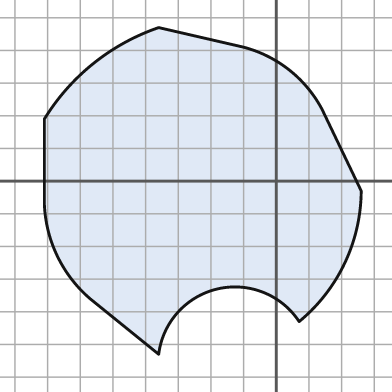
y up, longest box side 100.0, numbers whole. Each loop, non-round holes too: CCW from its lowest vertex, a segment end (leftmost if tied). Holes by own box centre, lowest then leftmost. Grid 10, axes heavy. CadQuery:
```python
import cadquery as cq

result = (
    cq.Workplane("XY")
    .moveTo(-36.0, -53.0)
    .threePointArc((-18.0, -33.0), (7.0, -43.0))
    .threePointArc((21.0, -25.0), (26.0, -3.0))
    .lineTo(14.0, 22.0)
    .threePointArc((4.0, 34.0), (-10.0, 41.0))
    .lineTo(-36.0, 47.0)
    .threePointArc((-56.0, 36.0), (-71.0, 19.0))
    .lineTo(-71.0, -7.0)
    .threePointArc((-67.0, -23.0), (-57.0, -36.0))
    .close()
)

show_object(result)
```